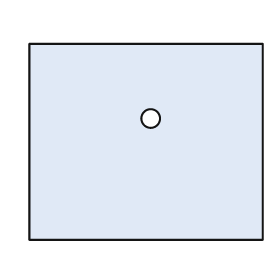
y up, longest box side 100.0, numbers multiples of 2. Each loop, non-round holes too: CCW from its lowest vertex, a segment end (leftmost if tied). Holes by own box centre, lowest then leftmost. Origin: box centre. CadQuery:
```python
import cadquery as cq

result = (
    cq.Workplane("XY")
    .moveTo(-50.0, -42.0)
    .lineTo(50.0, -42.0)
    .lineTo(50.0, 42.0)
    .lineTo(-50.0, 42.0)
    .close()
    .moveTo(2.0, 10.0)
    .circle(4.0)
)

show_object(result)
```